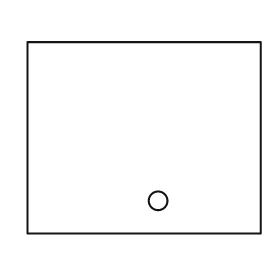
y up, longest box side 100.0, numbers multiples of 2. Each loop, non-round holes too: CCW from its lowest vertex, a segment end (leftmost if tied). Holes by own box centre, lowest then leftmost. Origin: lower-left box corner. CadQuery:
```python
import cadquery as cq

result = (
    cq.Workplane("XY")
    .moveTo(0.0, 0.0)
    .lineTo(100.0, 0.0)
    .lineTo(100.0, 82.0)
    .lineTo(0.0, 82.0)
    .close()
    .moveTo(56.0, 14.0)
    .circle(4.0)
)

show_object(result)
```